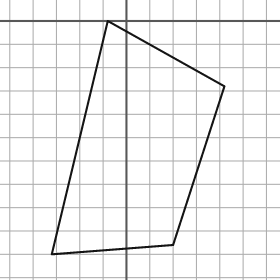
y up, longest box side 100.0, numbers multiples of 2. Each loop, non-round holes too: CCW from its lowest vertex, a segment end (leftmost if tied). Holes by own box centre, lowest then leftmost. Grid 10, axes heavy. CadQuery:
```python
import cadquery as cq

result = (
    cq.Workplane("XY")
    .moveTo(-32.0, -100.0)
    .lineTo(20.0, -96.0)
    .lineTo(42.0, -28.0)
    .lineTo(-8.0, 0.0)
    .close()
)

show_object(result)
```